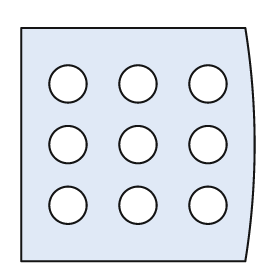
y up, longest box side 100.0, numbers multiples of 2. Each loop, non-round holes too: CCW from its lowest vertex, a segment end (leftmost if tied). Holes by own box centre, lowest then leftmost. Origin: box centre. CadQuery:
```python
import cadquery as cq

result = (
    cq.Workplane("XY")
    .moveTo(-50.0, -50.0)
    .lineTo(46.0, -50.0)
    .threePointArc((50.0, 0.0), (46.0, 50.0))
    .lineTo(-50.0, 50.0)
    .close()
    .moveTo(-30.0, -26.0)
    .circle(8.0)
    .moveTo(0.0, -26.0)
    .circle(8.0)
    .moveTo(30.0, -26.0)
    .circle(8.0)
    .moveTo(-30.0, 0.0)
    .circle(8.0)
    .moveTo(0.0, 0.0)
    .circle(8.0)
    .moveTo(30.0, 0.0)
    .circle(8.0)
    .moveTo(-30.0, 26.0)
    .circle(8.0)
    .moveTo(0.0, 26.0)
    .circle(8.0)
    .moveTo(30.0, 26.0)
    .circle(8.0)
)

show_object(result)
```